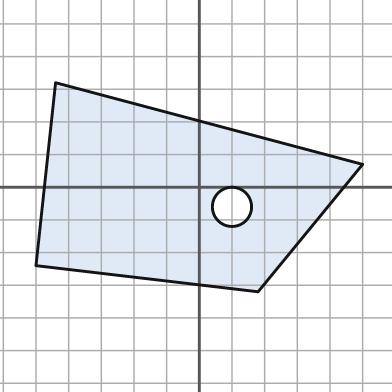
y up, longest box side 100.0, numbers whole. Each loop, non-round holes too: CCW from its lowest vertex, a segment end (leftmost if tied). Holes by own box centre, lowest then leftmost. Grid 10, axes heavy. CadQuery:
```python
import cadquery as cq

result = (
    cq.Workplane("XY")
    .moveTo(18.0, -32.0)
    .lineTo(50.0, 7.0)
    .lineTo(-44.0, 32.0)
    .lineTo(-50.0, -24.0)
    .close()
    .moveTo(10.0, -6.0)
    .circle(6.0)
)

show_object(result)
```